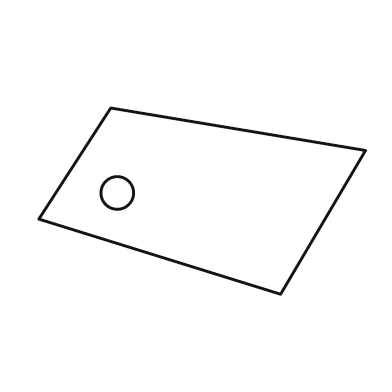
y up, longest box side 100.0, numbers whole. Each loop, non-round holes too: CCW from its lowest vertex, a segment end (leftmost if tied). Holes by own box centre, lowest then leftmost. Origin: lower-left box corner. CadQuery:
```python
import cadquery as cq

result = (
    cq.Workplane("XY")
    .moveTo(74.0, 0.0)
    .lineTo(100.0, 44.0)
    .lineTo(22.0, 57.0)
    .lineTo(0.0, 23.0)
    .close()
    .moveTo(24.0, 31.0)
    .circle(5.0)
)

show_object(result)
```